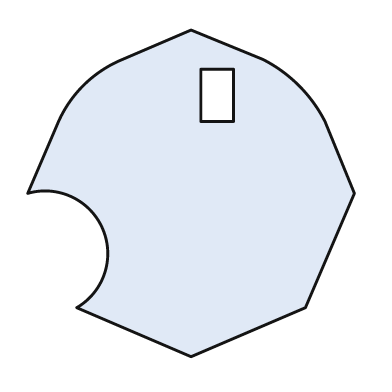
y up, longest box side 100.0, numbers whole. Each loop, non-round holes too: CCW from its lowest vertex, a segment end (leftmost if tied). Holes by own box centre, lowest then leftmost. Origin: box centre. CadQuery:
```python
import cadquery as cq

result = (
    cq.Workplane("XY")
    .moveTo(0.0, -50.0)
    .lineTo(35.0, -35.0)
    .lineTo(50.0, 0.0)
    .lineTo(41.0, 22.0)
    .threePointArc((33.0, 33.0), (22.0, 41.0))
    .lineTo(0.0, 50.0)
    .lineTo(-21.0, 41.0)
    .threePointArc((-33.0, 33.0), (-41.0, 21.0))
    .lineTo(-50.0, 0.0)
    .threePointArc((-27.0, -11.0), (-35.0, -35.0))
    .close()
    .moveTo(3.0, 22.0)
    .lineTo(13.0, 22.0)
    .lineTo(13.0, 38.0)
    .lineTo(3.0, 38.0)
    .close()
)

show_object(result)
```